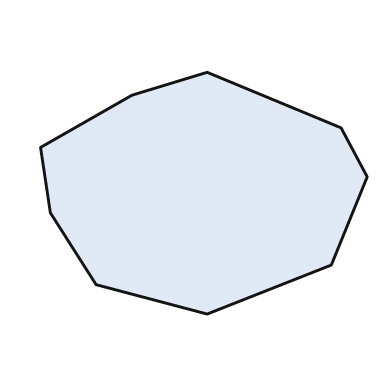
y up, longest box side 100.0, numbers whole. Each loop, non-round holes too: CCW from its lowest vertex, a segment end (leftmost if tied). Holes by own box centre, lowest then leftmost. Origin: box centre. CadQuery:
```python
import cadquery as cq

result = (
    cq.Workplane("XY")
    .moveTo(1.0, -37.0)
    .lineTo(39.0, -22.0)
    .lineTo(50.0, 5.0)
    .lineTo(42.0, 20.0)
    .lineTo(1.0, 37.0)
    .lineTo(-22.0, 30.0)
    .lineTo(-50.0, 14.0)
    .lineTo(-47.0, -6.0)
    .lineTo(-33.0, -28.0)
    .close()
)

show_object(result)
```